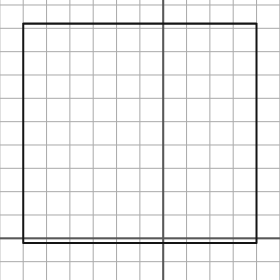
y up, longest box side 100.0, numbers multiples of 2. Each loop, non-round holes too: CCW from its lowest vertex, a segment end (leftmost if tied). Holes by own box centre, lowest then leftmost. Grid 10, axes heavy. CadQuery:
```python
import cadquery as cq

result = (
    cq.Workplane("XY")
    .moveTo(-60.0, -2.0)
    .lineTo(40.0, -2.0)
    .lineTo(40.0, 92.0)
    .lineTo(-60.0, 92.0)
    .close()
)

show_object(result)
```